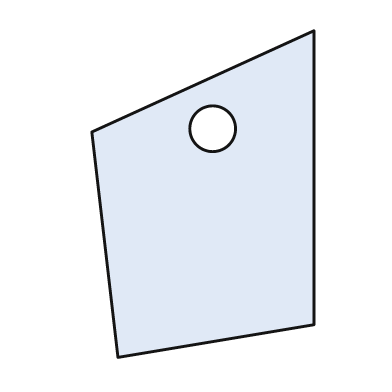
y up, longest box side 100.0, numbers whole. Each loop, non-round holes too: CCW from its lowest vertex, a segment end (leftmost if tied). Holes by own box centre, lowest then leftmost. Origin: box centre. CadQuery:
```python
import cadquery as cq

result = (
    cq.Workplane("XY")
    .moveTo(-26.0, -50.0)
    .lineTo(34.0, -40.0)
    .lineTo(34.0, 50.0)
    .lineTo(-34.0, 19.0)
    .close()
    .moveTo(3.0, 20.0)
    .circle(7.0)
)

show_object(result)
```